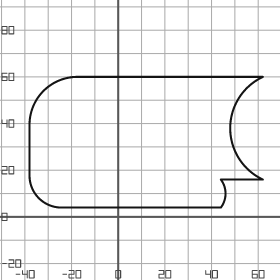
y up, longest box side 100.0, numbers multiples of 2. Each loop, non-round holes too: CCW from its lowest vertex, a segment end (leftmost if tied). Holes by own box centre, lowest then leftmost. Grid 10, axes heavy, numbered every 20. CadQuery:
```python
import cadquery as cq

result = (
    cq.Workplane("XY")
    .moveTo(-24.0, 4.0)
    .lineTo(44.0, 4.0)
    .threePointArc((46.0, 10.0), (44.0, 16.0))
    .lineTo(62.0, 16.0)
    .threePointArc((48.0, 38.0), (62.0, 60.0))
    .lineTo(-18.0, 60.0)
    .threePointArc((-32.0, 54.0), (-38.0, 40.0))
    .lineTo(-38.0, 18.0)
    .threePointArc((-34.0, 8.0), (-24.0, 4.0))
    .close()
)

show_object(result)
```